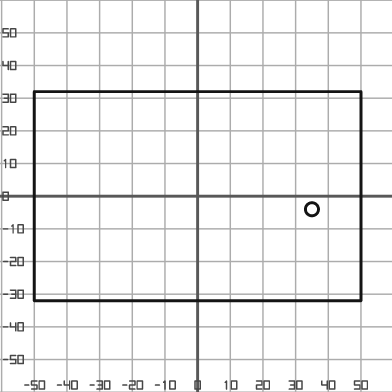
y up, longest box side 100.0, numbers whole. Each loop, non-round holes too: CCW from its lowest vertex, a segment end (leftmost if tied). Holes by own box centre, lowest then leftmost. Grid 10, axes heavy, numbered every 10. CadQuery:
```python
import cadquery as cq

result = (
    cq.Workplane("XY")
    .moveTo(-50.0, -32.0)
    .lineTo(50.0, -32.0)
    .lineTo(50.0, 32.0)
    .lineTo(-50.0, 32.0)
    .close()
    .moveTo(35.0, -4.0)
    .circle(2.0)
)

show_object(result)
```